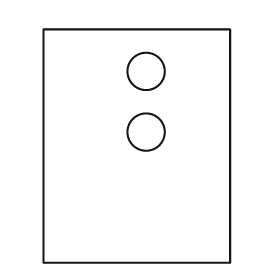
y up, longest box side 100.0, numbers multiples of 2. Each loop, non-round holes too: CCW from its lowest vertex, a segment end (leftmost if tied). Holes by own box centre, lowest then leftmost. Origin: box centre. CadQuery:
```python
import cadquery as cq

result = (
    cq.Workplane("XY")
    .moveTo(-40.0, -50.0)
    .lineTo(40.0, -50.0)
    .lineTo(40.0, 50.0)
    .lineTo(-40.0, 50.0)
    .close()
    .moveTo(4.0, 6.0)
    .circle(8.0)
    .moveTo(4.0, 32.0)
    .circle(8.0)
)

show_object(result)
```